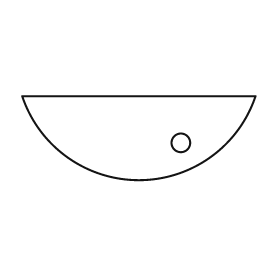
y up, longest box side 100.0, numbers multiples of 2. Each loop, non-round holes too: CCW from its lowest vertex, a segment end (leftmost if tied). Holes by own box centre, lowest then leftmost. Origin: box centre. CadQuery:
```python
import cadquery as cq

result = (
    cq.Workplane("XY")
    .moveTo(-50.0, 18.0)
    .threePointArc((0.0, -18.0), (50.0, 18.0))
    .close()
    .moveTo(18.0, -2.0)
    .circle(4.0)
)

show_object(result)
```